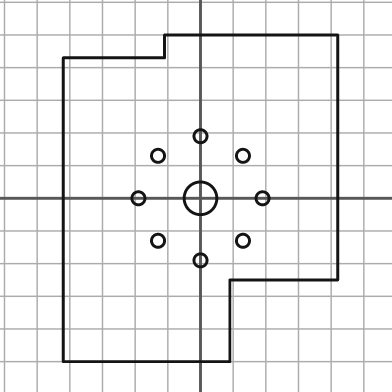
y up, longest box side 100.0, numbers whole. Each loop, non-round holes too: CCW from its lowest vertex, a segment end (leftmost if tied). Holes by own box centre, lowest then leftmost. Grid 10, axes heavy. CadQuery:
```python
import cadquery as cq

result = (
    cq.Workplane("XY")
    .moveTo(-42.0, -50.0)
    .lineTo(9.0, -50.0)
    .lineTo(9.0, -25.0)
    .lineTo(42.0, -25.0)
    .lineTo(42.0, 50.0)
    .lineTo(-11.0, 50.0)
    .lineTo(-11.0, 43.0)
    .lineTo(-42.0, 43.0)
    .close()
    .moveTo(0.0, -19.0)
    .circle(2.0)
    .moveTo(-13.0, -13.0)
    .circle(2.0)
    .moveTo(13.0, -13.0)
    .circle(2.0)
    .moveTo(-19.0, 0.0)
    .circle(2.0)
    .moveTo(0.0, 0.0)
    .circle(5.0)
    .moveTo(19.0, 0.0)
    .circle(2.0)
    .moveTo(-13.0, 13.0)
    .circle(2.0)
    .moveTo(13.0, 13.0)
    .circle(2.0)
    .moveTo(0.0, 19.0)
    .circle(2.0)
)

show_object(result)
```